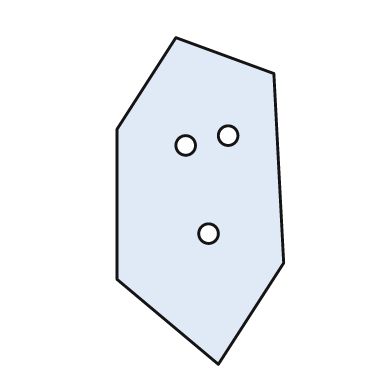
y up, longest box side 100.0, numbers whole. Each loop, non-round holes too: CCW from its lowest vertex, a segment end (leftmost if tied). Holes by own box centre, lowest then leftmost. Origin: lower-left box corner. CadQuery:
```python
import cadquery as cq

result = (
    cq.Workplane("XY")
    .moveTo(31.0, 0.0)
    .lineTo(51.0, 31.0)
    .lineTo(48.0, 89.0)
    .lineTo(18.0, 100.0)
    .lineTo(0.0, 72.0)
    .lineTo(0.0, 26.0)
    .close()
    .moveTo(28.0, 40.0)
    .circle(3.0)
    .moveTo(21.0, 67.0)
    .circle(3.0)
    .moveTo(34.0, 70.0)
    .circle(3.0)
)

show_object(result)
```